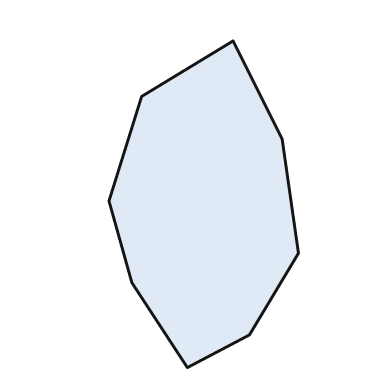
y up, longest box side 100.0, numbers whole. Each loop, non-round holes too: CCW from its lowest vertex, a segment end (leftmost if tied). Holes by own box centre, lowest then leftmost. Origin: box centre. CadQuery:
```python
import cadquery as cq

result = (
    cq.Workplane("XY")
    .moveTo(-5.0, -50.0)
    .lineTo(14.0, -40.0)
    .lineTo(29.0, -15.0)
    .lineTo(24.0, 20.0)
    .lineTo(9.0, 50.0)
    .lineTo(-19.0, 33.0)
    .lineTo(-29.0, 1.0)
    .lineTo(-22.0, -24.0)
    .close()
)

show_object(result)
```